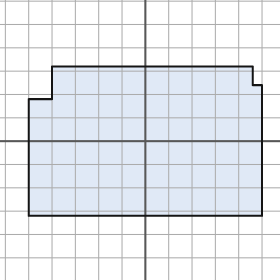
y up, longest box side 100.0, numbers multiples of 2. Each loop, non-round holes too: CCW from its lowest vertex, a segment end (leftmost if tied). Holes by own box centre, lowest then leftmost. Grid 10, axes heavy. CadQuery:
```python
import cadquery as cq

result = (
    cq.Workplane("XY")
    .moveTo(-50.0, -32.0)
    .lineTo(50.0, -32.0)
    .lineTo(50.0, 24.0)
    .lineTo(46.0, 24.0)
    .lineTo(46.0, 32.0)
    .lineTo(-40.0, 32.0)
    .lineTo(-40.0, 18.0)
    .lineTo(-50.0, 18.0)
    .close()
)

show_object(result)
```